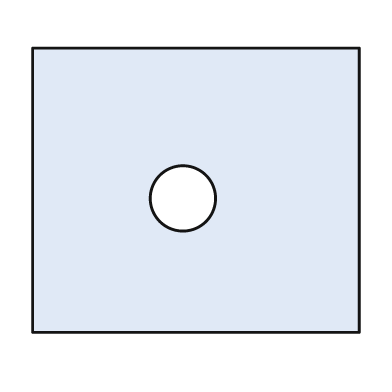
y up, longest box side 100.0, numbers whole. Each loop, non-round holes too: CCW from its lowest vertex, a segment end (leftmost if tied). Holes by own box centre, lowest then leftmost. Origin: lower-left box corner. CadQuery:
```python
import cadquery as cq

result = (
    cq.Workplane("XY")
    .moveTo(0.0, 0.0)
    .lineTo(100.0, 0.0)
    .lineTo(100.0, 87.0)
    .lineTo(0.0, 87.0)
    .close()
    .moveTo(46.0, 41.0)
    .circle(10.0)
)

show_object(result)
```